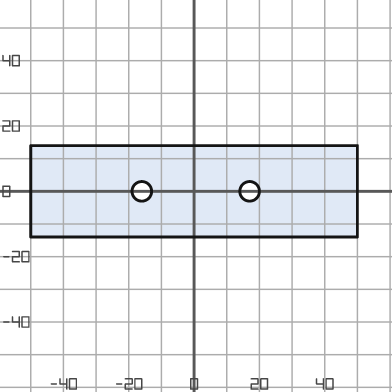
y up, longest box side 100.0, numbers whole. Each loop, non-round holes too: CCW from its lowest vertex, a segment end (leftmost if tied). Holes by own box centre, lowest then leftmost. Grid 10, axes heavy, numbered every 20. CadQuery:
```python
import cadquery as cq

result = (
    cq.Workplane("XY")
    .moveTo(-50.0, -14.0)
    .lineTo(50.0, -14.0)
    .lineTo(50.0, 14.0)
    .lineTo(-50.0, 14.0)
    .close()
    .moveTo(-16.0, 0.0)
    .circle(3.0)
    .moveTo(17.0, 0.0)
    .circle(3.0)
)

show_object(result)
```